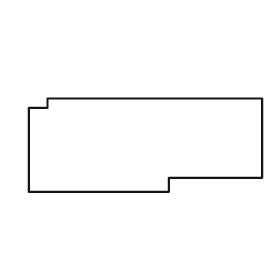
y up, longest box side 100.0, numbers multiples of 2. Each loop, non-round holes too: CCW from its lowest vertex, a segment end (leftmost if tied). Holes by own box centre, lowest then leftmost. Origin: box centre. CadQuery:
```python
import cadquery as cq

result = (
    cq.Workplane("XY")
    .moveTo(-50.0, -20.0)
    .lineTo(10.0, -20.0)
    .lineTo(10.0, -14.0)
    .lineTo(50.0, -14.0)
    .lineTo(50.0, 20.0)
    .lineTo(-42.0, 20.0)
    .lineTo(-42.0, 16.0)
    .lineTo(-50.0, 16.0)
    .close()
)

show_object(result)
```